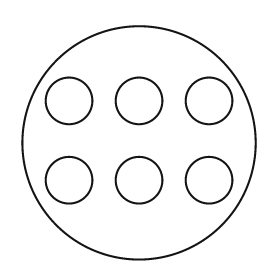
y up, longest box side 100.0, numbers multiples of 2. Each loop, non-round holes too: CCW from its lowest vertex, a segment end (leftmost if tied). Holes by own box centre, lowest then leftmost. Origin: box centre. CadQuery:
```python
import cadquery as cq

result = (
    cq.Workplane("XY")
    .moveTo(0.0, 0.0)
    .circle(50.0)
    .moveTo(-30.0, -16.0)
    .circle(10.0)
    .moveTo(0.0, -16.0)
    .circle(10.0)
    .moveTo(30.0, -16.0)
    .circle(10.0)
    .moveTo(-30.0, 18.0)
    .circle(10.0)
    .moveTo(0.0, 18.0)
    .circle(10.0)
    .moveTo(30.0, 18.0)
    .circle(10.0)
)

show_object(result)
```